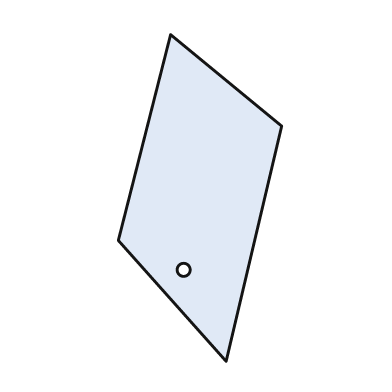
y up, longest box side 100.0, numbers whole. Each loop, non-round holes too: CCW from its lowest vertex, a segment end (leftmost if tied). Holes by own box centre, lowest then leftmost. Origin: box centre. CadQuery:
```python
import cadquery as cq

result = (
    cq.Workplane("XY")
    .moveTo(8.0, -50.0)
    .lineTo(25.0, 22.0)
    .lineTo(-9.0, 50.0)
    .lineTo(-25.0, -13.0)
    .close()
    .moveTo(-5.0, -22.0)
    .circle(2.0)
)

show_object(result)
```